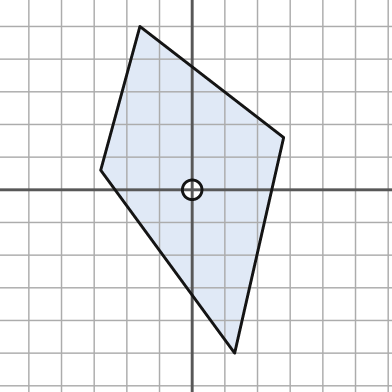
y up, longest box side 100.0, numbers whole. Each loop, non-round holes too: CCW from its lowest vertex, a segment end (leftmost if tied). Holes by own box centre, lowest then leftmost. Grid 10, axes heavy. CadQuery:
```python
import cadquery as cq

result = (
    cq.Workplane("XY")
    .moveTo(13.0, -50.0)
    .lineTo(28.0, 16.0)
    .lineTo(-16.0, 50.0)
    .lineTo(-28.0, 6.0)
    .close()
    .moveTo(0.0, 0.0)
    .circle(3.0)
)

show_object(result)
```